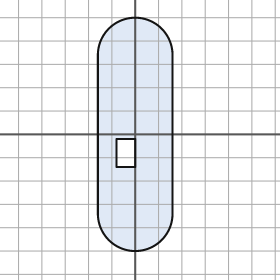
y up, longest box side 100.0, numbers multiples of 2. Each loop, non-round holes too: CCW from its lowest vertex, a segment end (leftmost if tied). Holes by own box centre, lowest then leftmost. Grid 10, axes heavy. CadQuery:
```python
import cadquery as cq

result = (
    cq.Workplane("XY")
    .moveTo(-16.0, -34.0)
    .threePointArc((0.0, -50.0), (16.0, -34.0))
    .lineTo(16.0, 34.0)
    .threePointArc((0.0, 50.0), (-16.0, 34.0))
    .close()
    .moveTo(-8.0, -14.0)
    .lineTo(0.0, -14.0)
    .lineTo(0.0, -2.0)
    .lineTo(-8.0, -2.0)
    .close()
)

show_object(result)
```